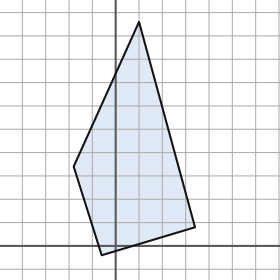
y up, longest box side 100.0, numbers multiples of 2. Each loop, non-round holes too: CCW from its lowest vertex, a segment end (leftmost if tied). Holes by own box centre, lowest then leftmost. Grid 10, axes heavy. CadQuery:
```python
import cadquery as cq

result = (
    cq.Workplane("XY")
    .moveTo(-6.0, -4.0)
    .lineTo(34.0, 8.0)
    .lineTo(10.0, 96.0)
    .lineTo(-18.0, 34.0)
    .close()
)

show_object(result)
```